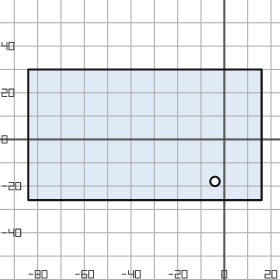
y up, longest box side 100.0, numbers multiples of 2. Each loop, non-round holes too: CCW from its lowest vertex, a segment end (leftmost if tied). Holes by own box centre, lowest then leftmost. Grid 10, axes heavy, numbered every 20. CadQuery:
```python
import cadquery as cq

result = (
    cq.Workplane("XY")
    .moveTo(-84.0, -26.0)
    .lineTo(16.0, -26.0)
    .lineTo(16.0, 30.0)
    .lineTo(-84.0, 30.0)
    .close()
    .moveTo(-4.0, -18.0)
    .circle(2.0)
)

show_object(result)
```